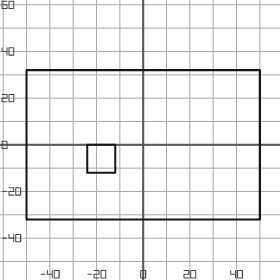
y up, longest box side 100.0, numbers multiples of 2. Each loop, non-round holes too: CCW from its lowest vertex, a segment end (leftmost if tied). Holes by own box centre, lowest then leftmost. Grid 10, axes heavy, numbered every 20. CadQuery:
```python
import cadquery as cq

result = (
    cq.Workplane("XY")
    .moveTo(-50.0, -32.0)
    .lineTo(50.0, -32.0)
    .lineTo(50.0, 32.0)
    .lineTo(-50.0, 32.0)
    .close()
    .moveTo(-24.0, -12.0)
    .lineTo(-12.0, -12.0)
    .lineTo(-12.0, 0.0)
    .lineTo(-24.0, 0.0)
    .close()
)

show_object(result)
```